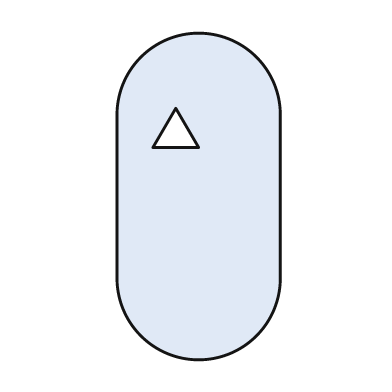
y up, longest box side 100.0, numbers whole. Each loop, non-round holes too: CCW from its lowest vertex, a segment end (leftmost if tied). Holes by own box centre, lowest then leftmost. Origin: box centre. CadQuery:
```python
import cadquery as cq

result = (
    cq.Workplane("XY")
    .moveTo(-25.0, -25.0)
    .threePointArc((0.0, -50.0), (25.0, -25.0))
    .lineTo(25.0, 25.0)
    .threePointArc((0.0, 50.0), (-25.0, 25.0))
    .close()
    .moveTo(-14.0, 15.0)
    .lineTo(0.0, 15.0)
    .lineTo(-7.0, 27.0)
    .close()
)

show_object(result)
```